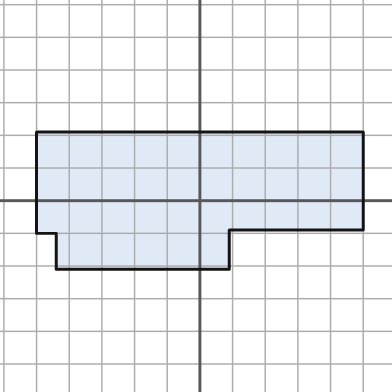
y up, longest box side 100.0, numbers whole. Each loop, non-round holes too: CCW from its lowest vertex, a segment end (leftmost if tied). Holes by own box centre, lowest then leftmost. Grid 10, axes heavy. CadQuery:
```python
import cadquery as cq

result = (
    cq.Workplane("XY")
    .moveTo(-44.0, -21.0)
    .lineTo(9.0, -21.0)
    .lineTo(9.0, -9.0)
    .lineTo(50.0, -9.0)
    .lineTo(50.0, 21.0)
    .lineTo(-50.0, 21.0)
    .lineTo(-50.0, -10.0)
    .lineTo(-44.0, -10.0)
    .close()
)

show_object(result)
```